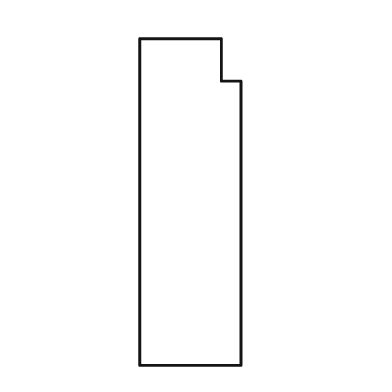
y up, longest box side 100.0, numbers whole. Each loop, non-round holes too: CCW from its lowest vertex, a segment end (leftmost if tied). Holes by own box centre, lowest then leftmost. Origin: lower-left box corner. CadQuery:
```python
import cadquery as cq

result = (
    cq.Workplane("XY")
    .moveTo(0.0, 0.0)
    .lineTo(31.0, 0.0)
    .lineTo(31.0, 87.0)
    .lineTo(25.0, 87.0)
    .lineTo(25.0, 100.0)
    .lineTo(0.0, 100.0)
    .close()
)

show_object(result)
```